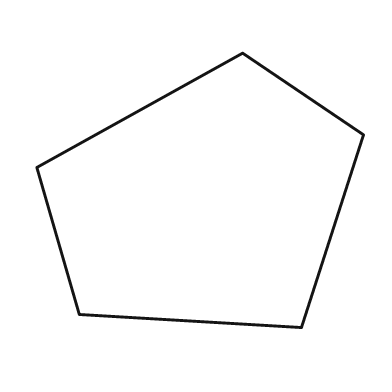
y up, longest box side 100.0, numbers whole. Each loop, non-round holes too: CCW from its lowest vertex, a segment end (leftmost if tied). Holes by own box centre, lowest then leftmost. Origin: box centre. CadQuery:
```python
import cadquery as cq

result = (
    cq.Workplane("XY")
    .moveTo(31.0, -42.0)
    .lineTo(50.0, 17.0)
    .lineTo(13.0, 42.0)
    .lineTo(-50.0, 7.0)
    .lineTo(-37.0, -38.0)
    .close()
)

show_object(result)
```